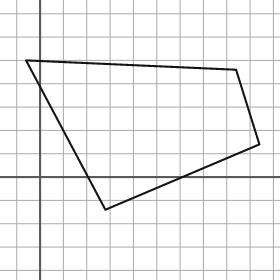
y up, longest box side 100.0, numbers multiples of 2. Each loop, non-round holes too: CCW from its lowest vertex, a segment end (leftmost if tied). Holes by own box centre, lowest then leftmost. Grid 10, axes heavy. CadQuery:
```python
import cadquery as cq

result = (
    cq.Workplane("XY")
    .moveTo(28.0, -14.0)
    .lineTo(94.0, 14.0)
    .lineTo(84.0, 46.0)
    .lineTo(-6.0, 50.0)
    .close()
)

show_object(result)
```